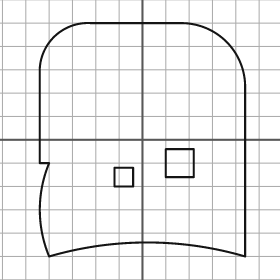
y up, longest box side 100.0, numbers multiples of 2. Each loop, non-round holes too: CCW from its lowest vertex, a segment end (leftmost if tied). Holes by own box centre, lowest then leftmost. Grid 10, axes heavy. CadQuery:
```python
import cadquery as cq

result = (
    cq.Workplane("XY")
    .moveTo(-40.0, -50.0)
    .threePointArc((2.0, -44.0), (44.0, -50.0))
    .lineTo(44.0, 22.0)
    .threePointArc((36.0, 42.0), (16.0, 50.0))
    .lineTo(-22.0, 50.0)
    .threePointArc((-38.0, 44.0), (-44.0, 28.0))
    .lineTo(-44.0, -10.0)
    .lineTo(-40.0, -10.0)
    .threePointArc((-44.0, -30.0), (-40.0, -50.0))
    .close()
    .moveTo(-12.0, -20.0)
    .lineTo(-4.0, -20.0)
    .lineTo(-4.0, -12.0)
    .lineTo(-12.0, -12.0)
    .close()
    .moveTo(10.0, -16.0)
    .lineTo(22.0, -16.0)
    .lineTo(22.0, -4.0)
    .lineTo(10.0, -4.0)
    .close()
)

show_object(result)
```